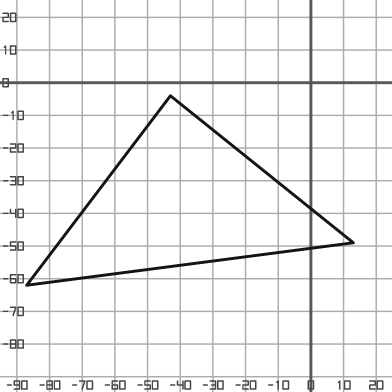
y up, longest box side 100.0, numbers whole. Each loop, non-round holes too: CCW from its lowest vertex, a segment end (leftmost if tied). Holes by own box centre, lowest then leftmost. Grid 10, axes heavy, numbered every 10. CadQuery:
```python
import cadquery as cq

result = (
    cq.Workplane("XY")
    .moveTo(-87.0, -62.0)
    .lineTo(13.0, -49.0)
    .lineTo(-43.0, -4.0)
    .close()
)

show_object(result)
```